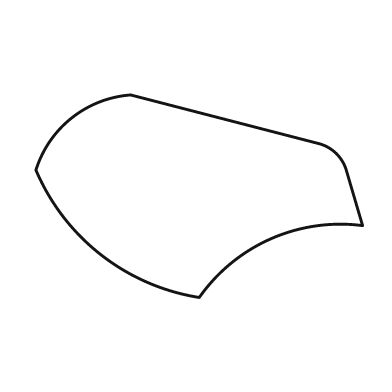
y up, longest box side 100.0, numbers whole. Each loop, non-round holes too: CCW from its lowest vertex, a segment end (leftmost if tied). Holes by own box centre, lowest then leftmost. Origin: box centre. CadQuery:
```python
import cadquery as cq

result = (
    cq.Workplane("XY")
    .moveTo(0.0, -31.0)
    .threePointArc((22.0, -13.0), (50.0, -9.0))
    .lineTo(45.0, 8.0)
    .threePointArc((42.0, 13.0), (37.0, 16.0))
    .lineTo(-21.0, 31.0)
    .threePointArc((-39.0, 24.0), (-50.0, 8.0))
    .threePointArc((-30.0, -18.0), (0.0, -31.0))
    .close()
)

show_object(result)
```